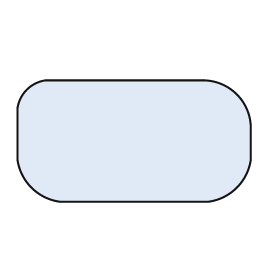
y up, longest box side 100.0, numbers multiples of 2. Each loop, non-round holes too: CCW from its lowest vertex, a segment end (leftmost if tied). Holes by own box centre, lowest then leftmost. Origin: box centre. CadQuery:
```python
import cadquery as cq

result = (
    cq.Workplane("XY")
    .moveTo(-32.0, -26.0)
    .lineTo(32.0, -26.0)
    .threePointArc((44.0, -20.0), (50.0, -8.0))
    .lineTo(50.0, 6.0)
    .threePointArc((44.0, 20.0), (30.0, 26.0))
    .lineTo(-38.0, 26.0)
    .threePointArc((-46.0, 22.0), (-50.0, 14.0))
    .lineTo(-50.0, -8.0)
    .threePointArc((-44.0, -20.0), (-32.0, -26.0))
    .close()
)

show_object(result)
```